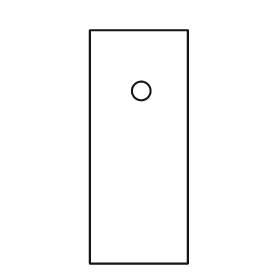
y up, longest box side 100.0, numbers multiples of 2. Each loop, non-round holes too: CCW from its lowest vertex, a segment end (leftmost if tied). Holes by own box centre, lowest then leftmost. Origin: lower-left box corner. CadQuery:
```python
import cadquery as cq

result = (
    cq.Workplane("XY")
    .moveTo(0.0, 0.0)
    .lineTo(42.0, 0.0)
    .lineTo(42.0, 100.0)
    .lineTo(0.0, 100.0)
    .close()
    .moveTo(22.0, 74.0)
    .circle(4.0)
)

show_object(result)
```